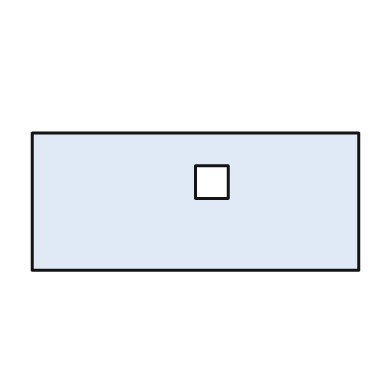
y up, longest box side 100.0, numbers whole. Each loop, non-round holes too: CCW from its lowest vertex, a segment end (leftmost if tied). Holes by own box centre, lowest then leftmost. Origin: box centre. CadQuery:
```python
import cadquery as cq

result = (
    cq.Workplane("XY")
    .moveTo(-50.0, -21.0)
    .lineTo(50.0, -21.0)
    .lineTo(50.0, 21.0)
    .lineTo(-50.0, 21.0)
    .close()
    .moveTo(0.0, 1.0)
    .lineTo(10.0, 1.0)
    .lineTo(10.0, 11.0)
    .lineTo(0.0, 11.0)
    .close()
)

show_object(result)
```